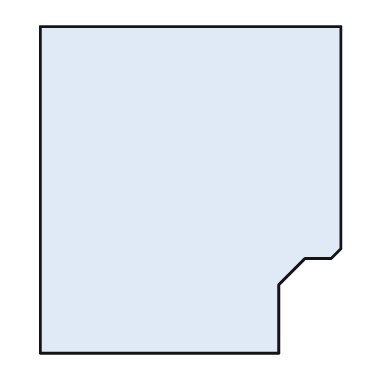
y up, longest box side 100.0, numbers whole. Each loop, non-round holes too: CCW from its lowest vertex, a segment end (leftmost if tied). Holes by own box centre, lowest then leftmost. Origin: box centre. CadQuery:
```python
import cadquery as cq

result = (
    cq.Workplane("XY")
    .moveTo(-46.0, -50.0)
    .lineTo(27.0, -50.0)
    .lineTo(27.0, -29.0)
    .lineTo(35.0, -21.0)
    .lineTo(43.0, -21.0)
    .lineTo(46.0, -18.0)
    .lineTo(46.0, 50.0)
    .lineTo(-46.0, 50.0)
    .close()
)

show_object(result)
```